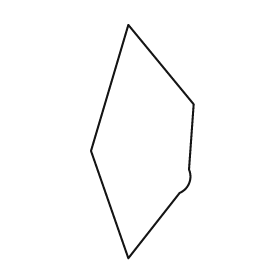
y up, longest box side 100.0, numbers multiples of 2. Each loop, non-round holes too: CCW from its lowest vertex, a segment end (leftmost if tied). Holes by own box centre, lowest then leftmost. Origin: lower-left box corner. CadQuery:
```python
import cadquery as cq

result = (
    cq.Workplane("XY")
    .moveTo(16.0, 0.0)
    .lineTo(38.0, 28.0)
    .threePointArc((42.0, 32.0), (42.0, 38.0))
    .lineTo(44.0, 66.0)
    .lineTo(16.0, 100.0)
    .lineTo(0.0, 46.0)
    .close()
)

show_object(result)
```